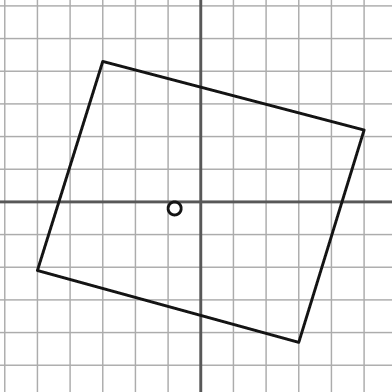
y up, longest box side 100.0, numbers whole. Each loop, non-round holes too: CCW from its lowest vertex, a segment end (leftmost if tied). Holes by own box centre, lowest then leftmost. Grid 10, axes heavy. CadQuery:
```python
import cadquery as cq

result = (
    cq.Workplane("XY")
    .moveTo(30.0, -43.0)
    .lineTo(50.0, 22.0)
    .lineTo(-30.0, 43.0)
    .lineTo(-50.0, -21.0)
    .close()
    .moveTo(-8.0, -2.0)
    .circle(2.0)
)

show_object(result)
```